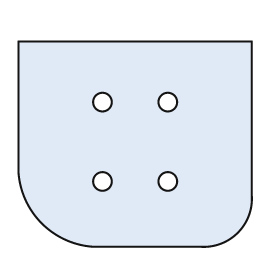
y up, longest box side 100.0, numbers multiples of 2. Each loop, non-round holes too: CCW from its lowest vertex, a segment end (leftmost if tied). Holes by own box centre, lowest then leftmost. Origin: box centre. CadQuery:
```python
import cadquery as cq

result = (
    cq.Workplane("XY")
    .moveTo(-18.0, -44.0)
    .lineTo(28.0, -44.0)
    .threePointArc((44.0, -38.0), (50.0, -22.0))
    .lineTo(50.0, 44.0)
    .lineTo(-50.0, 44.0)
    .lineTo(-50.0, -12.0)
    .threePointArc((-40.0, -34.0), (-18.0, -44.0))
    .close()
    .moveTo(-14.0, -16.0)
    .circle(4.0)
    .moveTo(14.0, -16.0)
    .circle(4.0)
    .moveTo(-14.0, 18.0)
    .circle(4.0)
    .moveTo(14.0, 18.0)
    .circle(4.0)
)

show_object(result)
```